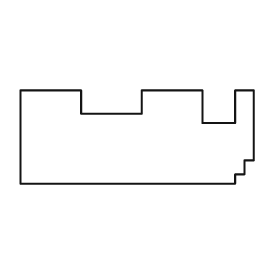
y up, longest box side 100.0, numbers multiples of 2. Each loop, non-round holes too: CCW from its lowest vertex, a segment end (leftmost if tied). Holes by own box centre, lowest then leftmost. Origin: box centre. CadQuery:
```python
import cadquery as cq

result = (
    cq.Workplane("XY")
    .moveTo(-50.0, -20.0)
    .lineTo(42.0, -20.0)
    .lineTo(42.0, -16.0)
    .lineTo(46.0, -16.0)
    .lineTo(46.0, -10.0)
    .lineTo(50.0, -10.0)
    .lineTo(50.0, 20.0)
    .lineTo(42.0, 20.0)
    .lineTo(42.0, 6.0)
    .lineTo(28.0, 6.0)
    .lineTo(28.0, 20.0)
    .lineTo(2.0, 20.0)
    .lineTo(2.0, 10.0)
    .lineTo(-24.0, 10.0)
    .lineTo(-24.0, 20.0)
    .lineTo(-50.0, 20.0)
    .close()
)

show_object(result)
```